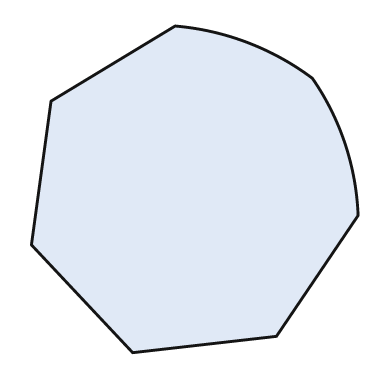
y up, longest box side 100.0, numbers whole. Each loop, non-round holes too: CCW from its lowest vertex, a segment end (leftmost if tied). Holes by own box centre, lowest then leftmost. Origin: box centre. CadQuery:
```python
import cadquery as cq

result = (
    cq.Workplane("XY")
    .moveTo(-19.0, -50.0)
    .lineTo(25.0, -45.0)
    .lineTo(50.0, -8.0)
    .threePointArc((46.0, 14.0), (36.0, 34.0))
    .threePointArc((16.0, 45.0), (-6.0, 50.0))
    .lineTo(-44.0, 27.0)
    .lineTo(-50.0, -17.0)
    .close()
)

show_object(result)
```